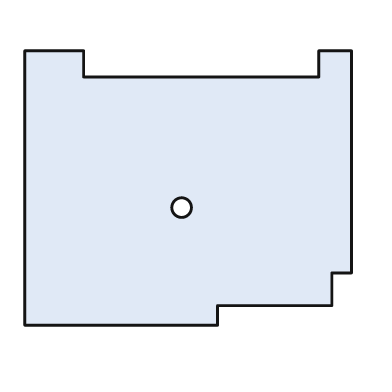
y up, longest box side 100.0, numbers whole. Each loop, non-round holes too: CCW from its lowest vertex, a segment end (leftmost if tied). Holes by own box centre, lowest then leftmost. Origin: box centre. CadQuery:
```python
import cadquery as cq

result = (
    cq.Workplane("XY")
    .moveTo(-50.0, -42.0)
    .lineTo(9.0, -42.0)
    .lineTo(9.0, -36.0)
    .lineTo(44.0, -36.0)
    .lineTo(44.0, -26.0)
    .lineTo(50.0, -26.0)
    .lineTo(50.0, 42.0)
    .lineTo(40.0, 42.0)
    .lineTo(40.0, 34.0)
    .lineTo(-32.0, 34.0)
    .lineTo(-32.0, 42.0)
    .lineTo(-50.0, 42.0)
    .close()
    .moveTo(-2.0, -6.0)
    .circle(3.0)
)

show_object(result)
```